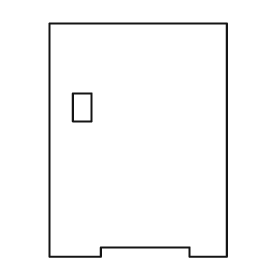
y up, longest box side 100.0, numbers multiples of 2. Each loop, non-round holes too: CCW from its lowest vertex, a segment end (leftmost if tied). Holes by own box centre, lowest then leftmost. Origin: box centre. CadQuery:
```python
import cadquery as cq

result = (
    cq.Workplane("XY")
    .moveTo(-38.0, -50.0)
    .lineTo(-16.0, -50.0)
    .lineTo(-16.0, -46.0)
    .lineTo(22.0, -46.0)
    .lineTo(22.0, -50.0)
    .lineTo(38.0, -50.0)
    .lineTo(38.0, 50.0)
    .lineTo(-38.0, 50.0)
    .close()
    .moveTo(-28.0, 8.0)
    .lineTo(-20.0, 8.0)
    .lineTo(-20.0, 20.0)
    .lineTo(-28.0, 20.0)
    .close()
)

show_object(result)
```